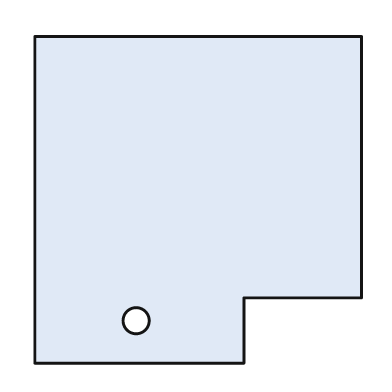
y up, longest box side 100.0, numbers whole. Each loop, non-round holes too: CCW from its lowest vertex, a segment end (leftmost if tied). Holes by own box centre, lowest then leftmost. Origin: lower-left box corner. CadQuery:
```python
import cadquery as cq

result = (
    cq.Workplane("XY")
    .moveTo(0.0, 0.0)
    .lineTo(64.0, 0.0)
    .lineTo(64.0, 20.0)
    .lineTo(100.0, 20.0)
    .lineTo(100.0, 100.0)
    .lineTo(0.0, 100.0)
    .close()
    .moveTo(31.0, 13.0)
    .circle(4.0)
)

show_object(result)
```